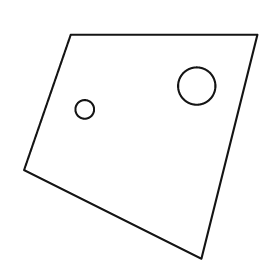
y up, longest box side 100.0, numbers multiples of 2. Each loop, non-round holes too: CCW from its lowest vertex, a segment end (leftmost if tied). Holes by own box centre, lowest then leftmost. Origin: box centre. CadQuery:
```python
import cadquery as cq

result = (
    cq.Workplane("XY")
    .moveTo(26.0, -48.0)
    .lineTo(50.0, 48.0)
    .lineTo(-30.0, 48.0)
    .lineTo(-50.0, -10.0)
    .close()
    .moveTo(-24.0, 16.0)
    .circle(4.0)
    .moveTo(24.0, 26.0)
    .circle(8.0)
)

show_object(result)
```